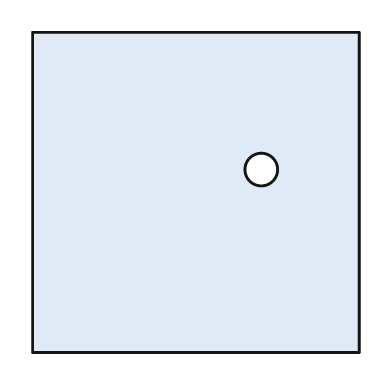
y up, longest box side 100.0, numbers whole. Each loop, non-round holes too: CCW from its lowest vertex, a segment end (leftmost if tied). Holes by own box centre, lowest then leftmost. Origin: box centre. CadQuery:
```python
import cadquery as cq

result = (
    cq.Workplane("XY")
    .moveTo(-50.0, -49.0)
    .lineTo(50.0, -49.0)
    .lineTo(50.0, 49.0)
    .lineTo(-50.0, 49.0)
    .close()
    .moveTo(20.0, 7.0)
    .circle(5.0)
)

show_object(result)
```